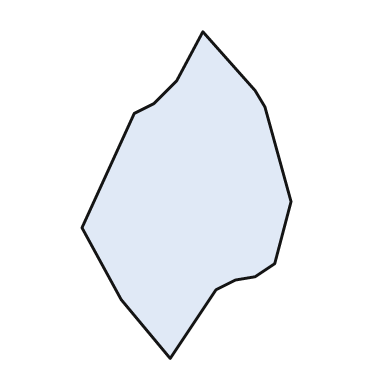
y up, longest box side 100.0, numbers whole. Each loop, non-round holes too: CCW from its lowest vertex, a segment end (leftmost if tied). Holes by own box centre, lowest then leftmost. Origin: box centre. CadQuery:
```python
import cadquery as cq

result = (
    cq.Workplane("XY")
    .moveTo(-5.0, -50.0)
    .lineTo(9.0, -29.0)
    .lineTo(15.0, -26.0)
    .lineTo(21.0, -25.0)
    .lineTo(27.0, -21.0)
    .lineTo(32.0, -2.0)
    .lineTo(24.0, 27.0)
    .lineTo(21.0, 32.0)
    .lineTo(5.0, 50.0)
    .lineTo(-3.0, 35.0)
    .lineTo(-10.0, 28.0)
    .lineTo(-16.0, 25.0)
    .lineTo(-32.0, -10.0)
    .lineTo(-20.0, -32.0)
    .close()
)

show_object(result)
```